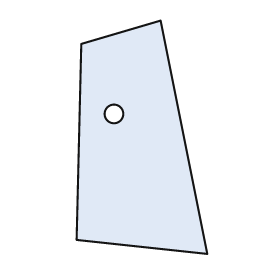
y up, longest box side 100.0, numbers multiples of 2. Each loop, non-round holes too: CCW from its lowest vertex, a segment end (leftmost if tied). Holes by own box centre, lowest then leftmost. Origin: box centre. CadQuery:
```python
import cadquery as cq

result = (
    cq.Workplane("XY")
    .moveTo(28.0, -50.0)
    .lineTo(8.0, 50.0)
    .lineTo(-26.0, 40.0)
    .lineTo(-28.0, -44.0)
    .close()
    .moveTo(-12.0, 10.0)
    .circle(4.0)
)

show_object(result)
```